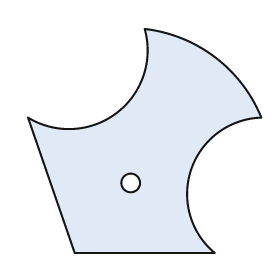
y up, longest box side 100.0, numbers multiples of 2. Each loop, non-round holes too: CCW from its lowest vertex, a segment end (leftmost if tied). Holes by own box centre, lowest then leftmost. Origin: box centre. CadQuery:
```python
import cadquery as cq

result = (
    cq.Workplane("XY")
    .moveTo(-30.0, -48.0)
    .lineTo(30.0, -48.0)
    .threePointArc((20.0, -12.0), (50.0, 10.0))
    .threePointArc((30.0, 36.0), (0.0, 48.0))
    .threePointArc((-12.0, 12.0), (-50.0, 10.0))
    .close()
    .moveTo(-6.0, -18.0)
    .circle(4.0)
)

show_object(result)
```